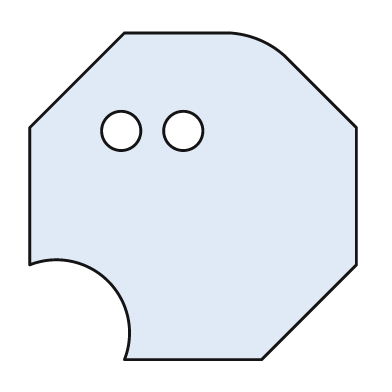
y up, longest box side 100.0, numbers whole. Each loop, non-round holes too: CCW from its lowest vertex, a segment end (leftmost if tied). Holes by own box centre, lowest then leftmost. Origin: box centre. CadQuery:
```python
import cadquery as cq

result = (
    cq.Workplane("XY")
    .moveTo(-21.0, -50.0)
    .lineTo(21.0, -50.0)
    .lineTo(50.0, -21.0)
    .lineTo(50.0, 21.0)
    .lineTo(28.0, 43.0)
    .threePointArc((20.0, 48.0), (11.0, 50.0))
    .lineTo(-21.0, 50.0)
    .lineTo(-50.0, 21.0)
    .lineTo(-50.0, -21.0)
    .threePointArc((-26.0, -26.0), (-21.0, -50.0))
    .close()
    .moveTo(-22.0, 20.0)
    .circle(6.0)
    .moveTo(-3.0, 20.0)
    .circle(6.0)
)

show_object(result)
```